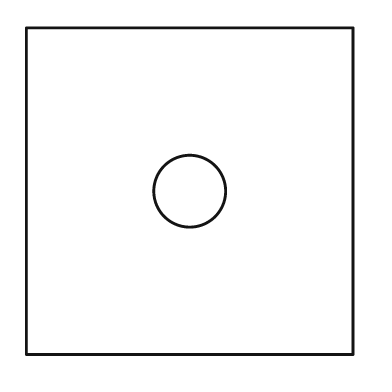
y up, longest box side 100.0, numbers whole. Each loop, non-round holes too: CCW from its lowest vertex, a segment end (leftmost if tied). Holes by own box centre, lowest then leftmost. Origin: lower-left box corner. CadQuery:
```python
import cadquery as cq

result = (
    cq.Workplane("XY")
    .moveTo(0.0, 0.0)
    .lineTo(100.0, 0.0)
    .lineTo(100.0, 100.0)
    .lineTo(0.0, 100.0)
    .close()
    .moveTo(50.0, 50.0)
    .circle(11.0)
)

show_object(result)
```